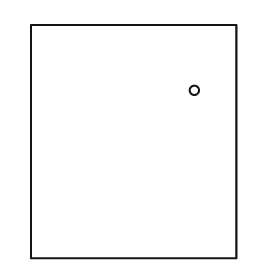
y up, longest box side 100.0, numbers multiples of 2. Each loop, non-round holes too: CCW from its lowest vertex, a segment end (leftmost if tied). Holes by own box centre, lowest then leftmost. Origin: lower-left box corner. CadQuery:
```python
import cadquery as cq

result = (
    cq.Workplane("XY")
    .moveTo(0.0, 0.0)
    .lineTo(88.0, 0.0)
    .lineTo(88.0, 100.0)
    .lineTo(0.0, 100.0)
    .close()
    .moveTo(70.0, 72.0)
    .circle(2.0)
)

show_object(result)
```